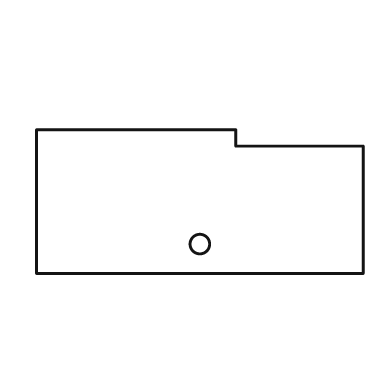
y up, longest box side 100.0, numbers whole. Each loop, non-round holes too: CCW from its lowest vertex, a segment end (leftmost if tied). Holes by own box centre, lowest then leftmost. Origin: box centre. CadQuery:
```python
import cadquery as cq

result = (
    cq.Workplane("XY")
    .moveTo(-50.0, -22.0)
    .lineTo(50.0, -22.0)
    .lineTo(50.0, 17.0)
    .lineTo(11.0, 17.0)
    .lineTo(11.0, 22.0)
    .lineTo(-50.0, 22.0)
    .close()
    .moveTo(0.0, -13.0)
    .circle(3.0)
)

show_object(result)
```